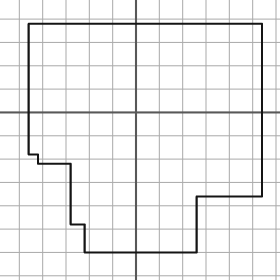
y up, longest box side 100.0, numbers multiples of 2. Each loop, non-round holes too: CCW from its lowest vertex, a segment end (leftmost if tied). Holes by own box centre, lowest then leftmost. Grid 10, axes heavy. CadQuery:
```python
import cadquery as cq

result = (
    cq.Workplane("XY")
    .moveTo(-22.0, -60.0)
    .lineTo(26.0, -60.0)
    .lineTo(26.0, -36.0)
    .lineTo(54.0, -36.0)
    .lineTo(54.0, 38.0)
    .lineTo(-46.0, 38.0)
    .lineTo(-46.0, -18.0)
    .lineTo(-42.0, -18.0)
    .lineTo(-42.0, -22.0)
    .lineTo(-28.0, -22.0)
    .lineTo(-28.0, -48.0)
    .lineTo(-22.0, -48.0)
    .close()
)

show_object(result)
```